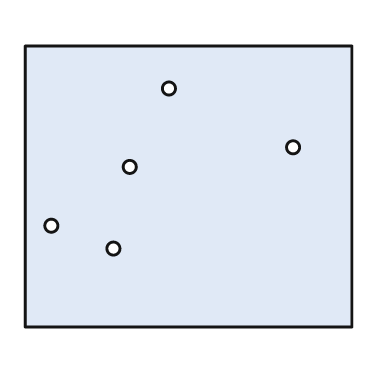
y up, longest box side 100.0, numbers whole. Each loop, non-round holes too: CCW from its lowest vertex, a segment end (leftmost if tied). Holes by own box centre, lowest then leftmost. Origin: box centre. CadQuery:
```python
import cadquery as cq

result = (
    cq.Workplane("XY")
    .moveTo(-50.0, -43.0)
    .lineTo(50.0, -43.0)
    .lineTo(50.0, 43.0)
    .lineTo(-50.0, 43.0)
    .close()
    .moveTo(-23.0, -19.0)
    .circle(2.0)
    .moveTo(-42.0, -12.0)
    .circle(2.0)
    .moveTo(-18.0, 6.0)
    .circle(2.0)
    .moveTo(32.0, 12.0)
    .circle(2.0)
    .moveTo(-6.0, 30.0)
    .circle(2.0)
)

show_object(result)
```